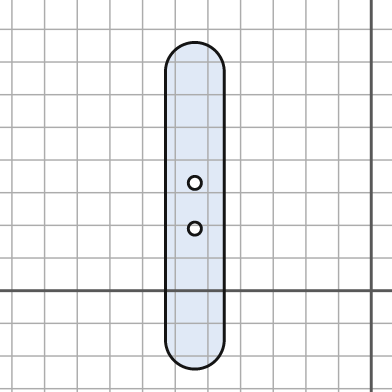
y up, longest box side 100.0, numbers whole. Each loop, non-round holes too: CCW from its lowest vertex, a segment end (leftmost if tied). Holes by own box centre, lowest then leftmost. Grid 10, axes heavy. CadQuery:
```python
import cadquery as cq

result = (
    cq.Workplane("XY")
    .moveTo(-63.0, -15.0)
    .threePointArc((-54.0, -24.0), (-45.0, -15.0))
    .lineTo(-45.0, 67.0)
    .threePointArc((-54.0, 76.0), (-63.0, 67.0))
    .close()
    .moveTo(-54.0, 19.0)
    .circle(2.0)
    .moveTo(-54.0, 33.0)
    .circle(2.0)
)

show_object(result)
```